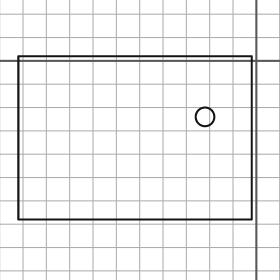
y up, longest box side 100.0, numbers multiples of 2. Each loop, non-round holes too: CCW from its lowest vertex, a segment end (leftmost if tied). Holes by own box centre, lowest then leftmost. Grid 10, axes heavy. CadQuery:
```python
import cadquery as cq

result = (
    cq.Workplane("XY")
    .moveTo(-102.0, -68.0)
    .lineTo(-2.0, -68.0)
    .lineTo(-2.0, 2.0)
    .lineTo(-102.0, 2.0)
    .close()
    .moveTo(-22.0, -24.0)
    .circle(4.0)
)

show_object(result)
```